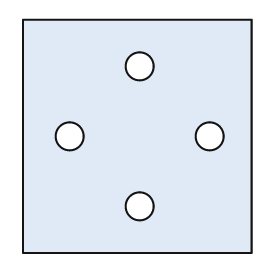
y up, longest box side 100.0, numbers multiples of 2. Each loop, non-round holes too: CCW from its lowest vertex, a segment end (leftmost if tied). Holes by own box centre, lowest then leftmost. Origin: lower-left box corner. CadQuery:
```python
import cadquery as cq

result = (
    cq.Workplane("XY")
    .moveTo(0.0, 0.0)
    .lineTo(98.0, 0.0)
    .lineTo(98.0, 100.0)
    .lineTo(0.0, 100.0)
    .close()
    .moveTo(50.0, 20.0)
    .circle(6.0)
    .moveTo(20.0, 50.0)
    .circle(6.0)
    .moveTo(80.0, 50.0)
    .circle(6.0)
    .moveTo(50.0, 80.0)
    .circle(6.0)
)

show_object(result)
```